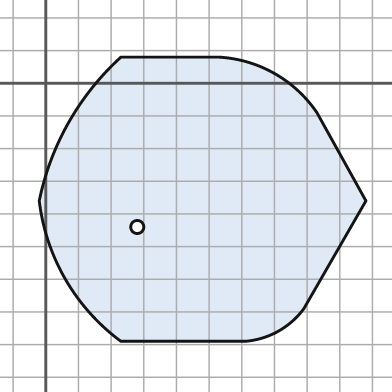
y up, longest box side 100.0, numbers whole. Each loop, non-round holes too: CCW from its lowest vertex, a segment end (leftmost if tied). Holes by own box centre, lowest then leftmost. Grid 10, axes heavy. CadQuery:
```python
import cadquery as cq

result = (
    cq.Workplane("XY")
    .moveTo(23.0, -79.0)
    .lineTo(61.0, -79.0)
    .threePointArc((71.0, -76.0), (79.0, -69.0))
    .lineTo(98.0, -36.0)
    .lineTo(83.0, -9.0)
    .threePointArc((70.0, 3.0), (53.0, 8.0))
    .lineTo(23.0, 8.0)
    .threePointArc((7.0, -12.0), (-2.0, -36.0))
    .threePointArc((6.0, -60.0), (23.0, -79.0))
    .close()
    .moveTo(28.0, -44.0)
    .circle(2.0)
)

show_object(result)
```